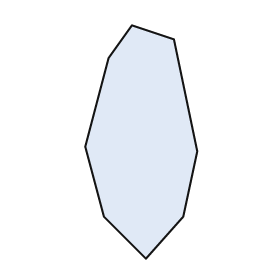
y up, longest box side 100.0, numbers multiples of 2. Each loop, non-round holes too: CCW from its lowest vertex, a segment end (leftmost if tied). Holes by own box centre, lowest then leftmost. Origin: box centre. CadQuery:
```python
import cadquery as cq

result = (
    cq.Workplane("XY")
    .moveTo(2.0, -50.0)
    .lineTo(18.0, -32.0)
    .lineTo(24.0, -4.0)
    .lineTo(14.0, 44.0)
    .lineTo(-4.0, 50.0)
    .lineTo(-14.0, 36.0)
    .lineTo(-24.0, -2.0)
    .lineTo(-16.0, -32.0)
    .close()
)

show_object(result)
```